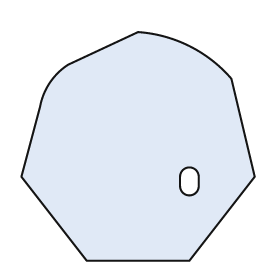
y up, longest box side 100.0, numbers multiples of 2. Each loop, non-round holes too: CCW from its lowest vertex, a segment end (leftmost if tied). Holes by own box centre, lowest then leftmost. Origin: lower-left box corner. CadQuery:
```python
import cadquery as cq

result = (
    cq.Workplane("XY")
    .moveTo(28.0, 0.0)
    .lineTo(72.0, 0.0)
    .lineTo(100.0, 36.0)
    .lineTo(90.0, 78.0)
    .threePointArc((72.0, 92.0), (50.0, 98.0))
    .lineTo(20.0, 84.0)
    .threePointArc((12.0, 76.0), (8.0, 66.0))
    .lineTo(0.0, 36.0)
    .close()
    .moveTo(68.0, 32.0)
    .threePointArc((72.0, 28.0), (76.0, 32.0))
    .lineTo(76.0, 36.0)
    .threePointArc((72.0, 40.0), (68.0, 36.0))
    .close()
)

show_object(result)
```